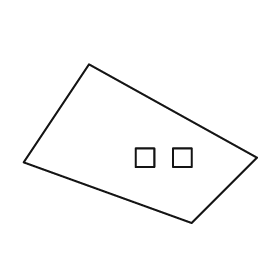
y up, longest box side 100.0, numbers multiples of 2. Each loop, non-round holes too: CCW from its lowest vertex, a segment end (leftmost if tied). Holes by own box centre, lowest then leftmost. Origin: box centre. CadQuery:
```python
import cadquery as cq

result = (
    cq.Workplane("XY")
    .moveTo(22.0, -34.0)
    .lineTo(50.0, -6.0)
    .lineTo(-22.0, 34.0)
    .lineTo(-50.0, -8.0)
    .close()
    .moveTo(-2.0, -10.0)
    .lineTo(6.0, -10.0)
    .lineTo(6.0, -2.0)
    .lineTo(-2.0, -2.0)
    .close()
    .moveTo(14.0, -10.0)
    .lineTo(22.0, -10.0)
    .lineTo(22.0, -2.0)
    .lineTo(14.0, -2.0)
    .close()
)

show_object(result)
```